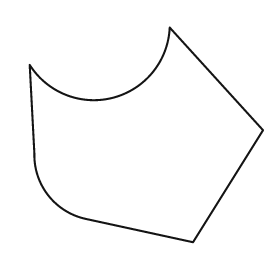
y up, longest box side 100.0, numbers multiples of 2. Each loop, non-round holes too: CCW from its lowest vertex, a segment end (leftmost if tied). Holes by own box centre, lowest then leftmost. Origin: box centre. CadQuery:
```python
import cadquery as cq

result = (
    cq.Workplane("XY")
    .moveTo(20.0, -46.0)
    .lineTo(50.0, 2.0)
    .lineTo(10.0, 46.0)
    .threePointArc((-14.0, 16.0), (-50.0, 30.0))
    .lineTo(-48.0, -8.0)
    .threePointArc((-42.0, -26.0), (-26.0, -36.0))
    .close()
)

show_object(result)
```